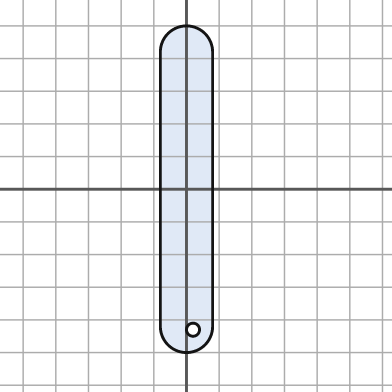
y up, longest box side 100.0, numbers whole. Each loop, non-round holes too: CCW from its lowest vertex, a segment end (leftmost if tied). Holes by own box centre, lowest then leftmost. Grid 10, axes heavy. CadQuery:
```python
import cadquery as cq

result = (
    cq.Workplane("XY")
    .moveTo(-8.0, -42.0)
    .threePointArc((0.0, -50.0), (8.0, -42.0))
    .lineTo(8.0, 42.0)
    .threePointArc((0.0, 50.0), (-8.0, 42.0))
    .close()
    .moveTo(2.0, -43.0)
    .circle(2.0)
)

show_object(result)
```